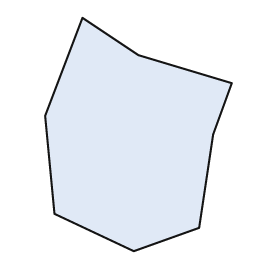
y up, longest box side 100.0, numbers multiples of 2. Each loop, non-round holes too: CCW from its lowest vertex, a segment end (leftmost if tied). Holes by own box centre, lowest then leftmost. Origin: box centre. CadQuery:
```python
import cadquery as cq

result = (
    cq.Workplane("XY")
    .moveTo(-2.0, -50.0)
    .lineTo(26.0, -40.0)
    .lineTo(32.0, 0.0)
    .lineTo(40.0, 22.0)
    .lineTo(0.0, 34.0)
    .lineTo(-24.0, 50.0)
    .lineTo(-40.0, 8.0)
    .lineTo(-36.0, -34.0)
    .close()
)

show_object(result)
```